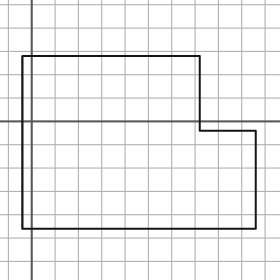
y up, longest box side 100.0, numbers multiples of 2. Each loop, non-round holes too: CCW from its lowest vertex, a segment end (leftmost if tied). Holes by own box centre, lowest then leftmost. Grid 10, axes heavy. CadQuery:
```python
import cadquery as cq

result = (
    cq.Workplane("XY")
    .moveTo(-4.0, -46.0)
    .lineTo(96.0, -46.0)
    .lineTo(96.0, -4.0)
    .lineTo(72.0, -4.0)
    .lineTo(72.0, 28.0)
    .lineTo(-4.0, 28.0)
    .close()
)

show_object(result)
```